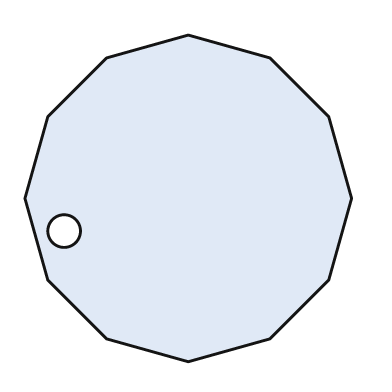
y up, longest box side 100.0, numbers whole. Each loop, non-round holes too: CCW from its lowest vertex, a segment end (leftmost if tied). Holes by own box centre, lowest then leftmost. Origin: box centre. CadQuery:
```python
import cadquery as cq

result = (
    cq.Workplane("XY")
    .moveTo(0.0, -50.0)
    .lineTo(25.0, -43.0)
    .lineTo(43.0, -25.0)
    .lineTo(50.0, 0.0)
    .lineTo(43.0, 25.0)
    .lineTo(25.0, 43.0)
    .lineTo(0.0, 50.0)
    .lineTo(-25.0, 43.0)
    .lineTo(-43.0, 25.0)
    .lineTo(-50.0, 0.0)
    .lineTo(-43.0, -25.0)
    .lineTo(-25.0, -43.0)
    .close()
    .moveTo(-38.0, -10.0)
    .circle(5.0)
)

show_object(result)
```